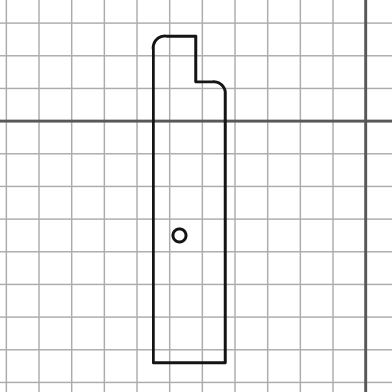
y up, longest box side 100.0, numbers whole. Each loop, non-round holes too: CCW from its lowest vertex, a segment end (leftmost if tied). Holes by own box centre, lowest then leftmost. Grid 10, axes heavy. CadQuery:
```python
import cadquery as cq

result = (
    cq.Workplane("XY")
    .moveTo(-65.0, -74.0)
    .lineTo(-43.0, -74.0)
    .lineTo(-43.0, 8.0)
    .threePointArc((-44.0, 11.0), (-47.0, 12.0))
    .lineTo(-52.0, 12.0)
    .lineTo(-52.0, 26.0)
    .lineTo(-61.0, 26.0)
    .threePointArc((-64.0, 25.0), (-65.0, 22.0))
    .close()
    .moveTo(-57.0, -35.0)
    .circle(2.0)
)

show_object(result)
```